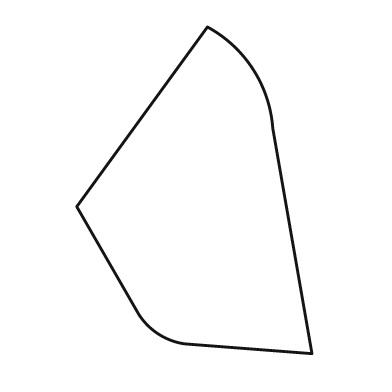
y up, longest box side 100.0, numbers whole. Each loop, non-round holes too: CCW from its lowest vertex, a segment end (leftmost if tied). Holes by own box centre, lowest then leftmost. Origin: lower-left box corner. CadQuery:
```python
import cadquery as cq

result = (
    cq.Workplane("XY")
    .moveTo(72.0, 0.0)
    .lineTo(60.0, 69.0)
    .threePointArc((54.0, 87.0), (40.0, 100.0))
    .lineTo(0.0, 45.0)
    .lineTo(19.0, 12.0)
    .threePointArc((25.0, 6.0), (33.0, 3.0))
    .close()
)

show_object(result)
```